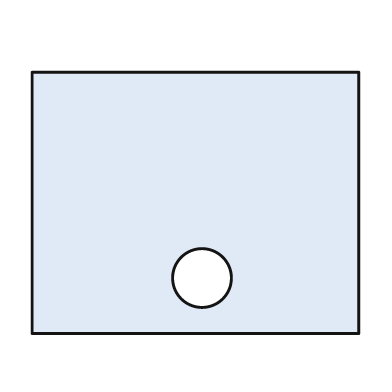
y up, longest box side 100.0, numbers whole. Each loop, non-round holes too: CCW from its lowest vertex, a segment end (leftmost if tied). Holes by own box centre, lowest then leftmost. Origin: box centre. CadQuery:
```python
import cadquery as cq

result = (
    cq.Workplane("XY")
    .moveTo(-50.0, -40.0)
    .lineTo(50.0, -40.0)
    .lineTo(50.0, 40.0)
    .lineTo(-50.0, 40.0)
    .close()
    .moveTo(2.0, -23.0)
    .circle(9.0)
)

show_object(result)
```